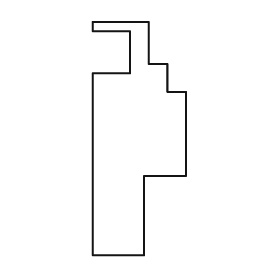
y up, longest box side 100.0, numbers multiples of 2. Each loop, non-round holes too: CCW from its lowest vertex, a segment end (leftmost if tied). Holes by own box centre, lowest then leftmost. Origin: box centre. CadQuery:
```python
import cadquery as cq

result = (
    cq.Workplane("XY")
    .moveTo(-20.0, -50.0)
    .lineTo(2.0, -50.0)
    .lineTo(2.0, -16.0)
    .lineTo(20.0, -16.0)
    .lineTo(20.0, 20.0)
    .lineTo(12.0, 20.0)
    .lineTo(12.0, 32.0)
    .lineTo(4.0, 32.0)
    .lineTo(4.0, 50.0)
    .lineTo(-20.0, 50.0)
    .lineTo(-20.0, 46.0)
    .lineTo(-4.0, 46.0)
    .lineTo(-4.0, 28.0)
    .lineTo(-20.0, 28.0)
    .close()
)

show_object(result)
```